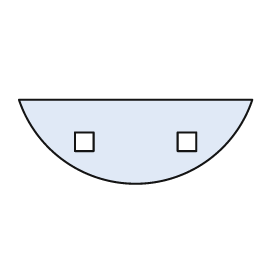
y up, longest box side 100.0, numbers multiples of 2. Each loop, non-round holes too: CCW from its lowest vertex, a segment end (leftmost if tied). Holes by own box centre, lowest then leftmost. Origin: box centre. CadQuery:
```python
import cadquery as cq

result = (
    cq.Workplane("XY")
    .moveTo(-50.0, 18.0)
    .threePointArc((0.0, -18.0), (50.0, 18.0))
    .close()
    .moveTo(-26.0, -4.0)
    .lineTo(-18.0, -4.0)
    .lineTo(-18.0, 4.0)
    .lineTo(-26.0, 4.0)
    .close()
    .moveTo(18.0, -4.0)
    .lineTo(26.0, -4.0)
    .lineTo(26.0, 4.0)
    .lineTo(18.0, 4.0)
    .close()
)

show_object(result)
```